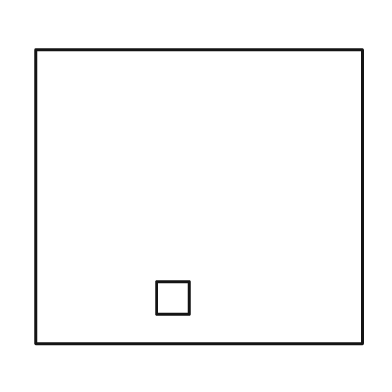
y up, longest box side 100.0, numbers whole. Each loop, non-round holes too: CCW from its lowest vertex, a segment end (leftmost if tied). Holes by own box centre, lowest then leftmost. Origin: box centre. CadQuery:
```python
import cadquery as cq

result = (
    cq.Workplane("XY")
    .moveTo(-50.0, -45.0)
    .lineTo(50.0, -45.0)
    .lineTo(50.0, 45.0)
    .lineTo(-50.0, 45.0)
    .close()
    .moveTo(-13.0, -36.0)
    .lineTo(-3.0, -36.0)
    .lineTo(-3.0, -26.0)
    .lineTo(-13.0, -26.0)
    .close()
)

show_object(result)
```